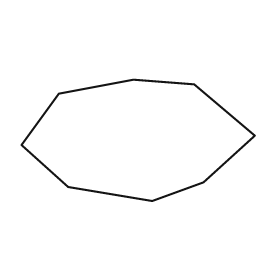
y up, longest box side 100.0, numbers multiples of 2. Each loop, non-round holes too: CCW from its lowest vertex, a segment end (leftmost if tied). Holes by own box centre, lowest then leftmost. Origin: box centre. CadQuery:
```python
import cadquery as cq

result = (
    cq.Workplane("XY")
    .moveTo(6.0, -26.0)
    .lineTo(28.0, -18.0)
    .lineTo(50.0, 2.0)
    .lineTo(24.0, 24.0)
    .lineTo(-2.0, 26.0)
    .lineTo(-34.0, 20.0)
    .lineTo(-50.0, -2.0)
    .lineTo(-30.0, -20.0)
    .close()
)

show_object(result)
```